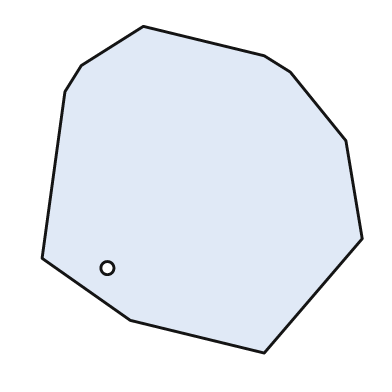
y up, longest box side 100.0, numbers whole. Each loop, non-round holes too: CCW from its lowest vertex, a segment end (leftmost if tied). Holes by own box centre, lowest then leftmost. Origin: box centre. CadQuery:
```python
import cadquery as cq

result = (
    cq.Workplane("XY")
    .moveTo(19.0, -50.0)
    .lineTo(49.0, -15.0)
    .lineTo(44.0, 15.0)
    .lineTo(27.0, 36.0)
    .lineTo(19.0, 41.0)
    .lineTo(-18.0, 50.0)
    .lineTo(-37.0, 38.0)
    .lineTo(-42.0, 30.0)
    .lineTo(-49.0, -21.0)
    .lineTo(-22.0, -40.0)
    .close()
    .moveTo(-29.0, -24.0)
    .circle(2.0)
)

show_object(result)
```